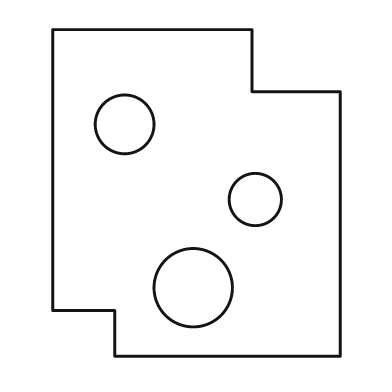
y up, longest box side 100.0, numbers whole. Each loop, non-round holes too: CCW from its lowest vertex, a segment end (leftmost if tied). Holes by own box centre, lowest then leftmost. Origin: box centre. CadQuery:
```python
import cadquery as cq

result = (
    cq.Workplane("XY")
    .moveTo(-25.0, -50.0)
    .lineTo(44.0, -50.0)
    .lineTo(44.0, 31.0)
    .lineTo(17.0, 31.0)
    .lineTo(17.0, 50.0)
    .lineTo(-44.0, 50.0)
    .lineTo(-44.0, -36.0)
    .lineTo(-25.0, -36.0)
    .close()
    .moveTo(-1.0, -29.0)
    .circle(12.0)
    .moveTo(18.0, -2.0)
    .circle(8.0)
    .moveTo(-22.0, 21.0)
    .circle(9.0)
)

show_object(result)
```